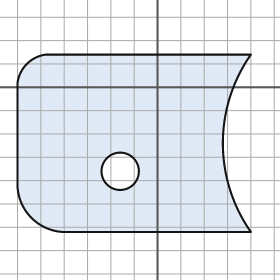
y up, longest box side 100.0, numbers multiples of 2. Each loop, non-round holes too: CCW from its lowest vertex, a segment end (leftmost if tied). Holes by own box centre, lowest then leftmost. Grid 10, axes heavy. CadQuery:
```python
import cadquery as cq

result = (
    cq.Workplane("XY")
    .moveTo(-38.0, -62.0)
    .lineTo(40.0, -62.0)
    .threePointArc((28.0, -24.0), (40.0, 14.0))
    .lineTo(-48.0, 14.0)
    .threePointArc((-56.0, 10.0), (-60.0, 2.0))
    .lineTo(-60.0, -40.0)
    .threePointArc((-54.0, -56.0), (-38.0, -62.0))
    .close()
    .moveTo(-16.0, -36.0)
    .circle(8.0)
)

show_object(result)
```